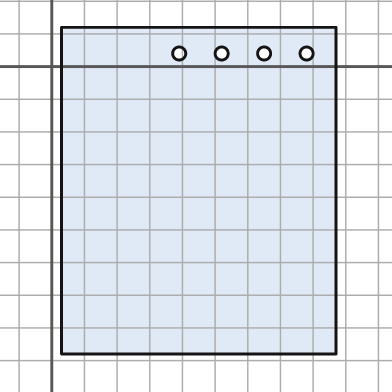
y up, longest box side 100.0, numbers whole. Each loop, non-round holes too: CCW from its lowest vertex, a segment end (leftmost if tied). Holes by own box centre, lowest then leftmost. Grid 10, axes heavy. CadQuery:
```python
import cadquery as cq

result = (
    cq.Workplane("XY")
    .moveTo(3.0, -88.0)
    .lineTo(87.0, -88.0)
    .lineTo(87.0, 12.0)
    .lineTo(3.0, 12.0)
    .close()
    .moveTo(39.0, 4.0)
    .circle(2.0)
    .moveTo(52.0, 4.0)
    .circle(2.0)
    .moveTo(65.0, 4.0)
    .circle(2.0)
    .moveTo(78.0, 4.0)
    .circle(2.0)
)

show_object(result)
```